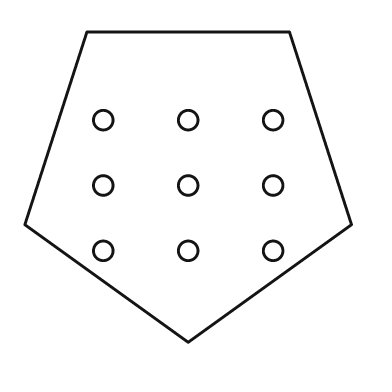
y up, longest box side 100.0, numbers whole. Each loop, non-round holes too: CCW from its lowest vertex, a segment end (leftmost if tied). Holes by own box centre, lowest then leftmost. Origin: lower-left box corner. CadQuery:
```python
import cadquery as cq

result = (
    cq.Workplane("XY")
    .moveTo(50.0, 0.0)
    .lineTo(100.0, 36.0)
    .lineTo(81.0, 95.0)
    .lineTo(19.0, 95.0)
    .lineTo(0.0, 36.0)
    .close()
    .moveTo(24.0, 28.0)
    .circle(3.0)
    .moveTo(50.0, 28.0)
    .circle(3.0)
    .moveTo(76.0, 28.0)
    .circle(3.0)
    .moveTo(24.0, 48.0)
    .circle(3.0)
    .moveTo(50.0, 48.0)
    .circle(3.0)
    .moveTo(76.0, 48.0)
    .circle(3.0)
    .moveTo(24.0, 68.0)
    .circle(3.0)
    .moveTo(50.0, 68.0)
    .circle(3.0)
    .moveTo(76.0, 68.0)
    .circle(3.0)
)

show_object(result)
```